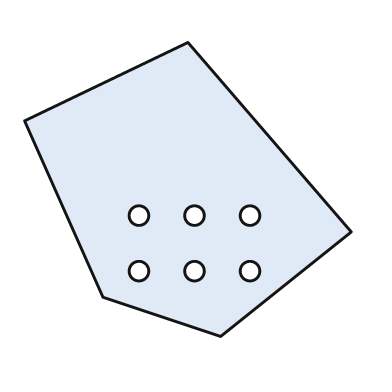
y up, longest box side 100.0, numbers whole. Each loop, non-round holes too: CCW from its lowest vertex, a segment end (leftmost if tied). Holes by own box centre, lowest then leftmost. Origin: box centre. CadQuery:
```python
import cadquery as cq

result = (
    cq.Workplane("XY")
    .moveTo(10.0, -45.0)
    .lineTo(50.0, -13.0)
    .lineTo(0.0, 45.0)
    .lineTo(-50.0, 21.0)
    .lineTo(-26.0, -33.0)
    .close()
    .moveTo(-15.0, -25.0)
    .circle(3.0)
    .moveTo(2.0, -25.0)
    .circle(3.0)
    .moveTo(19.0, -25.0)
    .circle(3.0)
    .moveTo(-15.0, -8.0)
    .circle(3.0)
    .moveTo(2.0, -8.0)
    .circle(3.0)
    .moveTo(19.0, -8.0)
    .circle(3.0)
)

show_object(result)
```